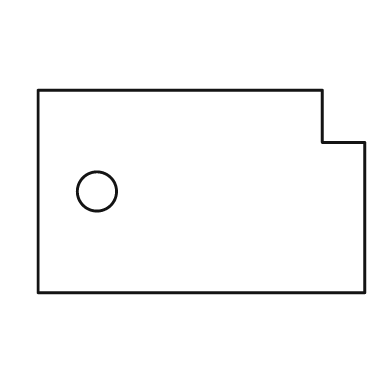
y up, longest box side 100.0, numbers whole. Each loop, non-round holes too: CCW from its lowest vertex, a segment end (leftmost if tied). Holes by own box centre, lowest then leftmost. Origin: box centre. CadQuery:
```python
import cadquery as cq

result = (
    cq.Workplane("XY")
    .moveTo(-50.0, -31.0)
    .lineTo(50.0, -31.0)
    .lineTo(50.0, 15.0)
    .lineTo(37.0, 15.0)
    .lineTo(37.0, 31.0)
    .lineTo(-50.0, 31.0)
    .close()
    .moveTo(-32.0, 0.0)
    .circle(6.0)
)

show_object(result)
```